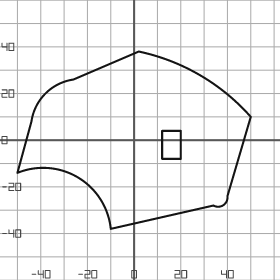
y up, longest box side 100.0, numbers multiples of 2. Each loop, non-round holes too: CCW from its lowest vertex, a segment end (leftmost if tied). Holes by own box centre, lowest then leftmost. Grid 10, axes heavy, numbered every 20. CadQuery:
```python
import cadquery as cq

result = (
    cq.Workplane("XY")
    .moveTo(-10.0, -38.0)
    .lineTo(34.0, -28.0)
    .threePointArc((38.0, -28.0), (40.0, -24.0))
    .lineTo(50.0, 10.0)
    .threePointArc((28.0, 28.0), (2.0, 38.0))
    .lineTo(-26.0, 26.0)
    .threePointArc((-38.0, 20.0), (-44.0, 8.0))
    .lineTo(-50.0, -14.0)
    .threePointArc((-24.0, -16.0), (-10.0, -38.0))
    .close()
    .moveTo(12.0, -8.0)
    .lineTo(20.0, -8.0)
    .lineTo(20.0, 4.0)
    .lineTo(12.0, 4.0)
    .close()
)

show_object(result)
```